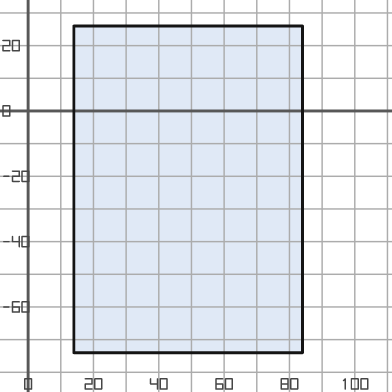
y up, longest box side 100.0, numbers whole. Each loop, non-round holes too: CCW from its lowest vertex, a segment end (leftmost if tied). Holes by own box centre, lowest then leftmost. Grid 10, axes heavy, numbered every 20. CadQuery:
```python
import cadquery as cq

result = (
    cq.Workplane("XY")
    .moveTo(14.0, -74.0)
    .lineTo(84.0, -74.0)
    .lineTo(84.0, 26.0)
    .lineTo(14.0, 26.0)
    .close()
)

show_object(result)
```